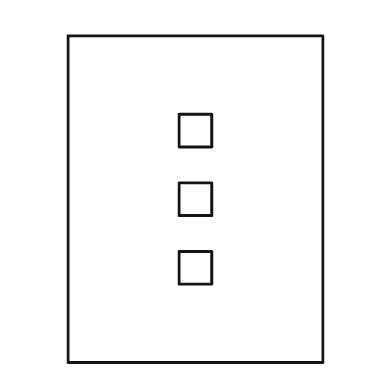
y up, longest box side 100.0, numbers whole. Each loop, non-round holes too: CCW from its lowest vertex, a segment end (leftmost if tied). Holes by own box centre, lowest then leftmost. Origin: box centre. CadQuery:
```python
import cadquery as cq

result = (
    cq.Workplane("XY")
    .moveTo(-39.0, -50.0)
    .lineTo(39.0, -50.0)
    .lineTo(39.0, 50.0)
    .lineTo(-39.0, 50.0)
    .close()
    .moveTo(-5.0, -26.0)
    .lineTo(5.0, -26.0)
    .lineTo(5.0, -16.0)
    .lineTo(-5.0, -16.0)
    .close()
    .moveTo(-5.0, -5.0)
    .lineTo(5.0, -5.0)
    .lineTo(5.0, 5.0)
    .lineTo(-5.0, 5.0)
    .close()
    .moveTo(-5.0, 16.0)
    .lineTo(5.0, 16.0)
    .lineTo(5.0, 26.0)
    .lineTo(-5.0, 26.0)
    .close()
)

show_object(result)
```